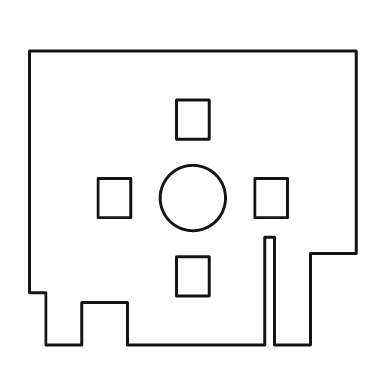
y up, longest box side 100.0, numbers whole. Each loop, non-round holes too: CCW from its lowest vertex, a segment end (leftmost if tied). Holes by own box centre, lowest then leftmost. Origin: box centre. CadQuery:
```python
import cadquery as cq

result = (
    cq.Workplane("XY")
    .moveTo(-45.0, -45.0)
    .lineTo(-34.0, -45.0)
    .lineTo(-34.0, -32.0)
    .lineTo(-20.0, -32.0)
    .lineTo(-20.0, -45.0)
    .lineTo(22.0, -45.0)
    .lineTo(22.0, -12.0)
    .lineTo(25.0, -12.0)
    .lineTo(25.0, -45.0)
    .lineTo(36.0, -45.0)
    .lineTo(36.0, -17.0)
    .lineTo(50.0, -17.0)
    .lineTo(50.0, 45.0)
    .lineTo(-50.0, 45.0)
    .lineTo(-50.0, -29.0)
    .lineTo(-45.0, -29.0)
    .close()
    .moveTo(-5.0, -30.0)
    .lineTo(5.0, -30.0)
    .lineTo(5.0, -18.0)
    .lineTo(-5.0, -18.0)
    .close()
    .moveTo(-29.0, -6.0)
    .lineTo(-19.0, -6.0)
    .lineTo(-19.0, 6.0)
    .lineTo(-29.0, 6.0)
    .close()
    .moveTo(0.0, 0.0)
    .circle(10.0)
    .moveTo(19.0, -6.0)
    .lineTo(29.0, -6.0)
    .lineTo(29.0, 6.0)
    .lineTo(19.0, 6.0)
    .close()
    .moveTo(-5.0, 18.0)
    .lineTo(5.0, 18.0)
    .lineTo(5.0, 30.0)
    .lineTo(-5.0, 30.0)
    .close()
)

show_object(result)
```